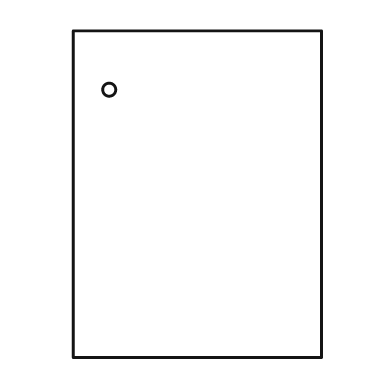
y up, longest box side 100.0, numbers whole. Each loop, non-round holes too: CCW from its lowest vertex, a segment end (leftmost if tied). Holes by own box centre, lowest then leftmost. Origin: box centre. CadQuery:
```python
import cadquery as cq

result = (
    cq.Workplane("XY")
    .moveTo(-38.0, -50.0)
    .lineTo(38.0, -50.0)
    .lineTo(38.0, 50.0)
    .lineTo(-38.0, 50.0)
    .close()
    .moveTo(-27.0, 32.0)
    .circle(2.0)
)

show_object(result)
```